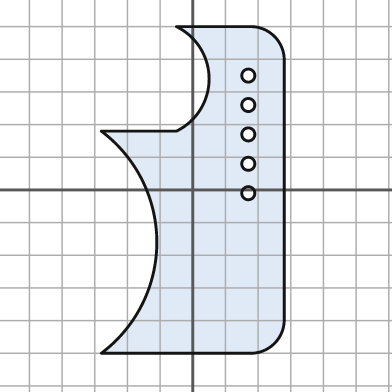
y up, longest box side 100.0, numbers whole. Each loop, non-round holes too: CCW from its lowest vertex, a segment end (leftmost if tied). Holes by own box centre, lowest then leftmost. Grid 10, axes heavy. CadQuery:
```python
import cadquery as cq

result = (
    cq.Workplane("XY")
    .moveTo(-28.0, -50.0)
    .lineTo(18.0, -50.0)
    .threePointArc((25.0, -47.0), (28.0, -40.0))
    .lineTo(28.0, 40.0)
    .threePointArc((25.0, 47.0), (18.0, 50.0))
    .lineTo(-5.0, 50.0)
    .threePointArc((5.0, 34.0), (-5.0, 18.0))
    .lineTo(-28.0, 18.0)
    .threePointArc((-11.0, -16.0), (-28.0, -50.0))
    .close()
    .moveTo(17.0, -1.0)
    .circle(2.0)
    .moveTo(17.0, 8.0)
    .circle(2.0)
    .moveTo(17.0, 17.0)
    .circle(2.0)
    .moveTo(17.0, 26.0)
    .circle(2.0)
    .moveTo(17.0, 35.0)
    .circle(2.0)
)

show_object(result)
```